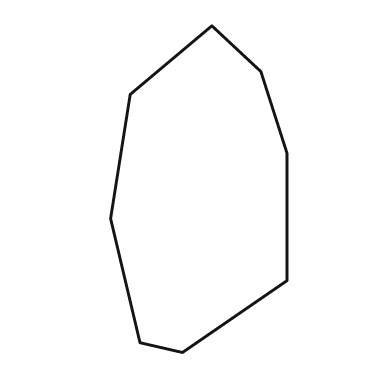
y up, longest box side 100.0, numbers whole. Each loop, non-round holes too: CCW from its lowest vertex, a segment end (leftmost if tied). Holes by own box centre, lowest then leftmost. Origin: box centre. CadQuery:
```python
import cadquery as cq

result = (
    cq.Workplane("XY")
    .moveTo(-5.0, -50.0)
    .lineTo(27.0, -28.0)
    .lineTo(27.0, 11.0)
    .lineTo(19.0, 36.0)
    .lineTo(4.0, 50.0)
    .lineTo(-21.0, 29.0)
    .lineTo(-27.0, -9.0)
    .lineTo(-18.0, -47.0)
    .close()
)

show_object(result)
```